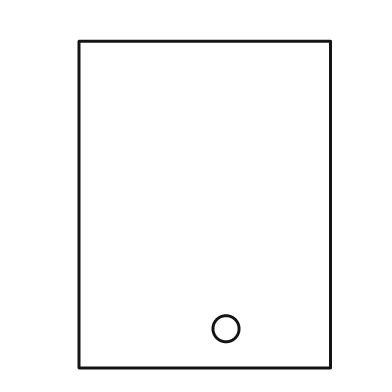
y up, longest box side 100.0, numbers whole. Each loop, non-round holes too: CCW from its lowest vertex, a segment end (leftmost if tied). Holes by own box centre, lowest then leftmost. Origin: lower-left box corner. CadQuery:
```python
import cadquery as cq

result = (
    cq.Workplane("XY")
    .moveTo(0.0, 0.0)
    .lineTo(77.0, 0.0)
    .lineTo(77.0, 100.0)
    .lineTo(0.0, 100.0)
    .close()
    .moveTo(45.0, 12.0)
    .circle(4.0)
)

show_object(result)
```